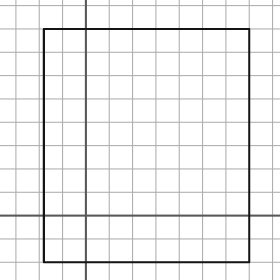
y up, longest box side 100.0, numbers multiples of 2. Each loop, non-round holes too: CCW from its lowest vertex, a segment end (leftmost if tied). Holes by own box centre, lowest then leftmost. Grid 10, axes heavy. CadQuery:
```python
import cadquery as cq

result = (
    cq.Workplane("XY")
    .moveTo(-18.0, -20.0)
    .lineTo(70.0, -20.0)
    .lineTo(70.0, 80.0)
    .lineTo(-18.0, 80.0)
    .close()
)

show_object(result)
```